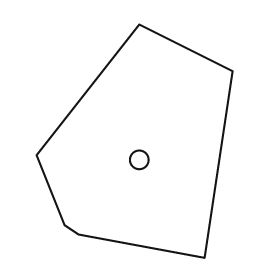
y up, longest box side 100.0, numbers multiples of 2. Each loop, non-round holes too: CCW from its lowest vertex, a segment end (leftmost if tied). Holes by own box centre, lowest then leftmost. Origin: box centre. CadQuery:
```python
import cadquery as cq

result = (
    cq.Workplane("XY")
    .moveTo(30.0, -50.0)
    .lineTo(42.0, 30.0)
    .lineTo(2.0, 50.0)
    .lineTo(-42.0, -6.0)
    .lineTo(-30.0, -36.0)
    .lineTo(-24.0, -40.0)
    .close()
    .moveTo(2.0, -8.0)
    .circle(4.0)
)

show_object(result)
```